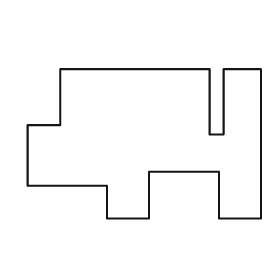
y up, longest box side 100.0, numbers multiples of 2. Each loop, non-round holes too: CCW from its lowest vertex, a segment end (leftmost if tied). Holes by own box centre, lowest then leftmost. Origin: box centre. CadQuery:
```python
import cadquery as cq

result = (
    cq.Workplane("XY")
    .moveTo(-16.0, -32.0)
    .lineTo(2.0, -32.0)
    .lineTo(2.0, -12.0)
    .lineTo(32.0, -12.0)
    .lineTo(32.0, -32.0)
    .lineTo(50.0, -32.0)
    .lineTo(50.0, 32.0)
    .lineTo(34.0, 32.0)
    .lineTo(34.0, 4.0)
    .lineTo(28.0, 4.0)
    .lineTo(28.0, 32.0)
    .lineTo(-36.0, 32.0)
    .lineTo(-36.0, 8.0)
    .lineTo(-50.0, 8.0)
    .lineTo(-50.0, -18.0)
    .lineTo(-16.0, -18.0)
    .close()
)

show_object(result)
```